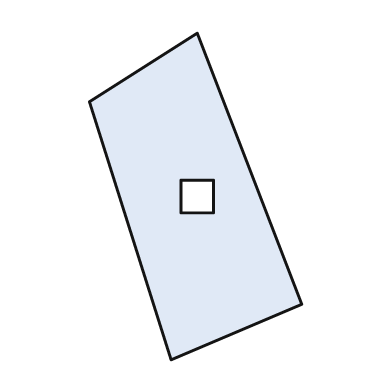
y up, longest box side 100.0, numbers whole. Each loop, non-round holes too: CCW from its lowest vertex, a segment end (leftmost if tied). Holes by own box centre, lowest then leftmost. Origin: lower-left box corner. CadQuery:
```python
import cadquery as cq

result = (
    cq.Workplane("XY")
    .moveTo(25.0, 0.0)
    .lineTo(65.0, 17.0)
    .lineTo(33.0, 100.0)
    .lineTo(0.0, 79.0)
    .close()
    .moveTo(28.0, 45.0)
    .lineTo(38.0, 45.0)
    .lineTo(38.0, 55.0)
    .lineTo(28.0, 55.0)
    .close()
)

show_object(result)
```